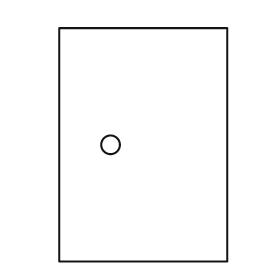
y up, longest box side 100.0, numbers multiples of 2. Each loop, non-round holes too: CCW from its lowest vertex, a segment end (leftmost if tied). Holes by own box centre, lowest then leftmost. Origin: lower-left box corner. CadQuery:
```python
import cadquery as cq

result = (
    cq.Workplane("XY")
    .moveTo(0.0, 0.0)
    .lineTo(72.0, 0.0)
    .lineTo(72.0, 100.0)
    .lineTo(0.0, 100.0)
    .close()
    .moveTo(22.0, 50.0)
    .circle(4.0)
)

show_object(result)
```